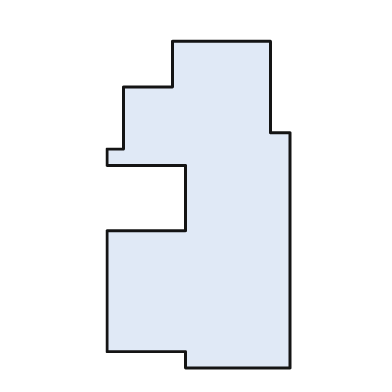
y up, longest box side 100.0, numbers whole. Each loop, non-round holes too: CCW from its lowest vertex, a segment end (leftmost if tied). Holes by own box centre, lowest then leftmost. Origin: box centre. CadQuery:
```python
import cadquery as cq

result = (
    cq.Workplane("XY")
    .moveTo(-4.0, -50.0)
    .lineTo(28.0, -50.0)
    .lineTo(28.0, 22.0)
    .lineTo(22.0, 22.0)
    .lineTo(22.0, 50.0)
    .lineTo(-8.0, 50.0)
    .lineTo(-8.0, 36.0)
    .lineTo(-23.0, 36.0)
    .lineTo(-23.0, 17.0)
    .lineTo(-28.0, 17.0)
    .lineTo(-28.0, 12.0)
    .lineTo(-4.0, 12.0)
    .lineTo(-4.0, -8.0)
    .lineTo(-28.0, -8.0)
    .lineTo(-28.0, -45.0)
    .lineTo(-4.0, -45.0)
    .close()
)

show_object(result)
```